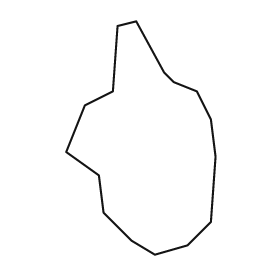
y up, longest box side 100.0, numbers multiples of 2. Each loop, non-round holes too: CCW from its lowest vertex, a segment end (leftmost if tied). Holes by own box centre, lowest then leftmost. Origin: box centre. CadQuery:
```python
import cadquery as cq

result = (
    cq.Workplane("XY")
    .moveTo(6.0, -50.0)
    .lineTo(20.0, -46.0)
    .lineTo(30.0, -36.0)
    .lineTo(32.0, -8.0)
    .lineTo(30.0, 8.0)
    .lineTo(24.0, 20.0)
    .lineTo(14.0, 24.0)
    .lineTo(10.0, 28.0)
    .lineTo(-2.0, 50.0)
    .lineTo(-10.0, 48.0)
    .lineTo(-12.0, 20.0)
    .lineTo(-24.0, 14.0)
    .lineTo(-32.0, -6.0)
    .lineTo(-18.0, -16.0)
    .lineTo(-16.0, -32.0)
    .lineTo(-4.0, -44.0)
    .close()
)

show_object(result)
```